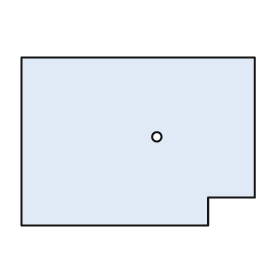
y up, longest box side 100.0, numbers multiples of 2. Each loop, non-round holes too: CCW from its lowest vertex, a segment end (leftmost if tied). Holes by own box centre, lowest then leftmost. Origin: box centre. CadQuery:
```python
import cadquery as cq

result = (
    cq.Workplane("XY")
    .moveTo(-50.0, -36.0)
    .lineTo(30.0, -36.0)
    .lineTo(30.0, -24.0)
    .lineTo(50.0, -24.0)
    .lineTo(50.0, 36.0)
    .lineTo(-50.0, 36.0)
    .close()
    .moveTo(8.0, 2.0)
    .circle(2.0)
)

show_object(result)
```